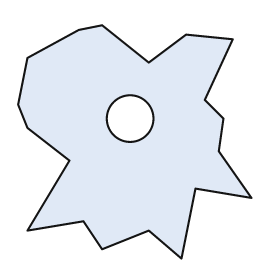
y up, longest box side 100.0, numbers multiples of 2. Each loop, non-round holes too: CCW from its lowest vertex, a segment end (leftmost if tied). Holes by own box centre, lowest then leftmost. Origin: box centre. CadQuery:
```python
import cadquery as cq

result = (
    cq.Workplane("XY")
    .moveTo(20.0, -50.0)
    .lineTo(26.0, -20.0)
    .lineTo(50.0, -24.0)
    .lineTo(36.0, -4.0)
    .lineTo(38.0, 10.0)
    .lineTo(30.0, 18.0)
    .lineTo(42.0, 44.0)
    .lineTo(22.0, 46.0)
    .lineTo(6.0, 34.0)
    .lineTo(-14.0, 50.0)
    .lineTo(-24.0, 48.0)
    .lineTo(-46.0, 36.0)
    .lineTo(-50.0, 16.0)
    .lineTo(-46.0, 6.0)
    .lineTo(-28.0, -8.0)
    .lineTo(-46.0, -38.0)
    .lineTo(-22.0, -34.0)
    .lineTo(-14.0, -46.0)
    .lineTo(6.0, -38.0)
    .close()
    .moveTo(-2.0, 10.0)
    .circle(10.0)
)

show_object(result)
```